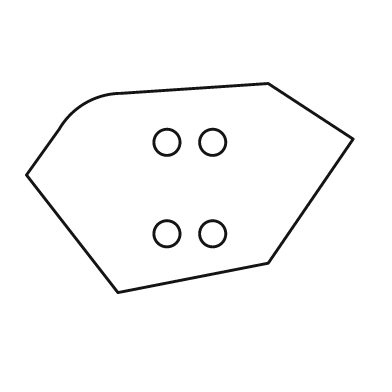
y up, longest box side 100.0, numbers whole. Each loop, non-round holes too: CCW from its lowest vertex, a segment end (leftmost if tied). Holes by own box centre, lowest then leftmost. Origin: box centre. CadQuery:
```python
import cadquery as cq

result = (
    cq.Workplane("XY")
    .moveTo(-22.0, -32.0)
    .lineTo(24.0, -23.0)
    .lineTo(50.0, 15.0)
    .lineTo(24.0, 32.0)
    .lineTo(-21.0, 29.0)
    .threePointArc((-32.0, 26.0), (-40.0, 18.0))
    .lineTo(-50.0, 4.0)
    .close()
    .moveTo(-7.0, -14.0)
    .circle(4.0)
    .moveTo(7.0, -14.0)
    .circle(4.0)
    .moveTo(-7.0, 14.0)
    .circle(4.0)
    .moveTo(7.0, 14.0)
    .circle(4.0)
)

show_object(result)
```